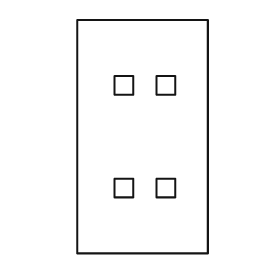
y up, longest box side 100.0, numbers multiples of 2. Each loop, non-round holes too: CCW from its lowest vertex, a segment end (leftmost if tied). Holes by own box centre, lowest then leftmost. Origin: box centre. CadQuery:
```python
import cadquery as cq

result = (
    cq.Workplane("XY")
    .moveTo(-28.0, -50.0)
    .lineTo(28.0, -50.0)
    .lineTo(28.0, 50.0)
    .lineTo(-28.0, 50.0)
    .close()
    .moveTo(-12.0, -26.0)
    .lineTo(-4.0, -26.0)
    .lineTo(-4.0, -18.0)
    .lineTo(-12.0, -18.0)
    .close()
    .moveTo(6.0, -26.0)
    .lineTo(14.0, -26.0)
    .lineTo(14.0, -18.0)
    .lineTo(6.0, -18.0)
    .close()
    .moveTo(-12.0, 18.0)
    .lineTo(-4.0, 18.0)
    .lineTo(-4.0, 26.0)
    .lineTo(-12.0, 26.0)
    .close()
    .moveTo(6.0, 18.0)
    .lineTo(14.0, 18.0)
    .lineTo(14.0, 26.0)
    .lineTo(6.0, 26.0)
    .close()
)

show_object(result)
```